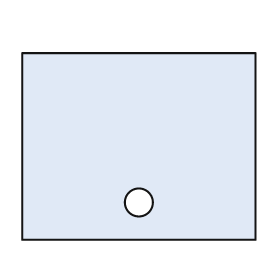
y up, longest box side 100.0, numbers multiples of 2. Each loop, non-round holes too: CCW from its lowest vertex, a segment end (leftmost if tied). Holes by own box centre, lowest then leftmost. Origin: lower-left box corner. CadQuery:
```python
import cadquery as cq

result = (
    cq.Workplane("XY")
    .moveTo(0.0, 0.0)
    .lineTo(100.0, 0.0)
    .lineTo(100.0, 80.0)
    .lineTo(0.0, 80.0)
    .close()
    .moveTo(50.0, 16.0)
    .circle(6.0)
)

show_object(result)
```